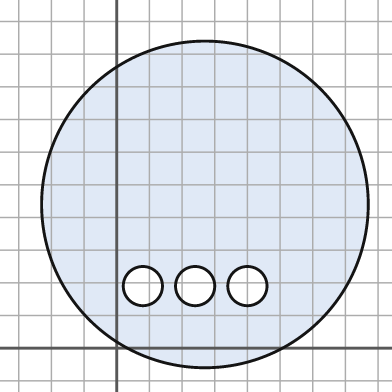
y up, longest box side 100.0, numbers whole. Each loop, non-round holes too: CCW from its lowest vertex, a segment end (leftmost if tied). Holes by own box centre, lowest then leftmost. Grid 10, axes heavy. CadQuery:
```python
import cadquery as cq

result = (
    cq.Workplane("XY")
    .moveTo(27.0, 44.0)
    .circle(50.0)
    .moveTo(8.0, 19.0)
    .circle(6.0)
    .moveTo(24.0, 19.0)
    .circle(6.0)
    .moveTo(40.0, 19.0)
    .circle(6.0)
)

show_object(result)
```